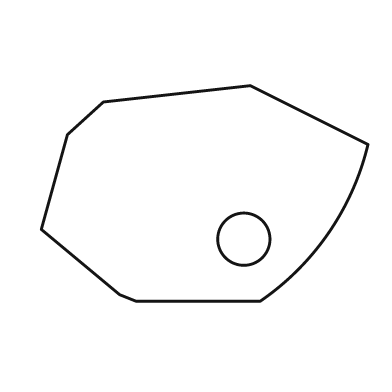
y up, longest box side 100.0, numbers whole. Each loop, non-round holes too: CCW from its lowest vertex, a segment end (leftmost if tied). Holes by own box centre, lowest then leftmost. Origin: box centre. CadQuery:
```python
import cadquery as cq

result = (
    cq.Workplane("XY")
    .moveTo(-21.0, -33.0)
    .lineTo(17.0, -33.0)
    .threePointArc((38.0, -12.0), (50.0, 15.0))
    .lineTo(14.0, 33.0)
    .lineTo(-31.0, 28.0)
    .lineTo(-42.0, 18.0)
    .lineTo(-50.0, -11.0)
    .lineTo(-26.0, -31.0)
    .close()
    .moveTo(12.0, -14.0)
    .circle(8.0)
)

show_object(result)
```